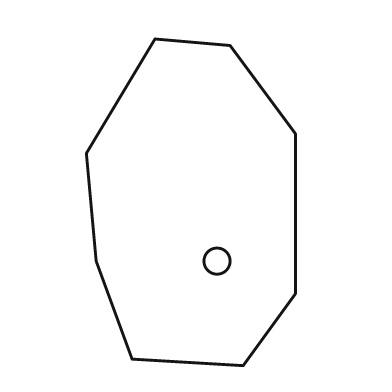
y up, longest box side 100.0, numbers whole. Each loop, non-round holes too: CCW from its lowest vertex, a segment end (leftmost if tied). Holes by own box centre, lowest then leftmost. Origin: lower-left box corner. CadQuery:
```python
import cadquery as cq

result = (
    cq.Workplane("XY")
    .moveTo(48.0, 0.0)
    .lineTo(64.0, 22.0)
    .lineTo(64.0, 71.0)
    .lineTo(44.0, 98.0)
    .lineTo(21.0, 100.0)
    .lineTo(0.0, 65.0)
    .lineTo(3.0, 32.0)
    .lineTo(14.0, 2.0)
    .close()
    .moveTo(40.0, 32.0)
    .circle(4.0)
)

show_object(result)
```